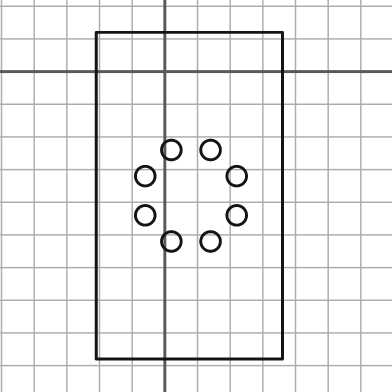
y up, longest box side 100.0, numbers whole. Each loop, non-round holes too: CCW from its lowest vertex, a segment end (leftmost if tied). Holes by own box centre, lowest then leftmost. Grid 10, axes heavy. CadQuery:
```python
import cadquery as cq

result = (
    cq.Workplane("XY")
    .moveTo(-21.0, -88.0)
    .lineTo(36.0, -88.0)
    .lineTo(36.0, 12.0)
    .lineTo(-21.0, 12.0)
    .close()
    .moveTo(2.0, -52.0)
    .circle(3.0)
    .moveTo(14.0, -52.0)
    .circle(3.0)
    .moveTo(-6.0, -44.0)
    .circle(3.0)
    .moveTo(22.0, -44.0)
    .circle(3.0)
    .moveTo(-6.0, -32.0)
    .circle(3.0)
    .moveTo(22.0, -32.0)
    .circle(3.0)
    .moveTo(2.0, -24.0)
    .circle(3.0)
    .moveTo(14.0, -24.0)
    .circle(3.0)
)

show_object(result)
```